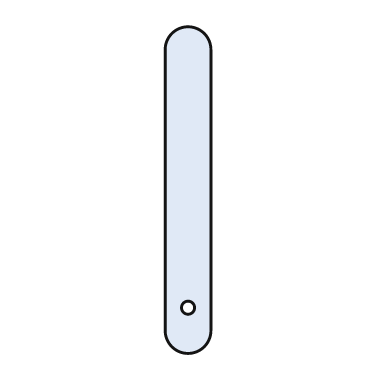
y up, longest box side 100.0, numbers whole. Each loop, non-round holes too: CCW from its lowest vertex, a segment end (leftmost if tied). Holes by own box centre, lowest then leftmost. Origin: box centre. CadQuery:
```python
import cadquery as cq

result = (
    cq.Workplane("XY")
    .moveTo(-7.0, -43.0)
    .threePointArc((0.0, -50.0), (7.0, -43.0))
    .lineTo(7.0, 43.0)
    .threePointArc((0.0, 50.0), (-7.0, 43.0))
    .close()
    .moveTo(0.0, -36.0)
    .circle(2.0)
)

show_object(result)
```